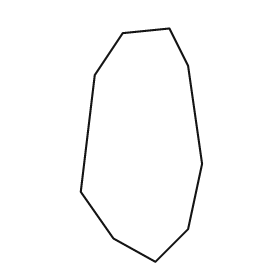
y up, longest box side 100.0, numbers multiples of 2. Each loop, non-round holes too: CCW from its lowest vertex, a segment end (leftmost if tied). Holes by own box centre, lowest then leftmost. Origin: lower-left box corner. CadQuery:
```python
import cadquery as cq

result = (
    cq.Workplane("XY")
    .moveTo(32.0, 0.0)
    .lineTo(46.0, 14.0)
    .lineTo(52.0, 42.0)
    .lineTo(46.0, 84.0)
    .lineTo(38.0, 100.0)
    .lineTo(18.0, 98.0)
    .lineTo(6.0, 80.0)
    .lineTo(0.0, 30.0)
    .lineTo(14.0, 10.0)
    .close()
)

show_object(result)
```